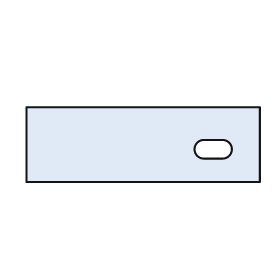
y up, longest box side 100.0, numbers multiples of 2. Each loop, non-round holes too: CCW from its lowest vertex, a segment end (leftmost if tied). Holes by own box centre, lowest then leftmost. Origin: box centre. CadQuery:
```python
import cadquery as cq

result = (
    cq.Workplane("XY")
    .moveTo(-50.0, -16.0)
    .lineTo(50.0, -16.0)
    .lineTo(50.0, 16.0)
    .lineTo(-50.0, 16.0)
    .close()
    .moveTo(26.0, -6.0)
    .lineTo(34.0, -6.0)
    .threePointArc((38.0, -2.0), (34.0, 2.0))
    .lineTo(26.0, 2.0)
    .threePointArc((22.0, -2.0), (26.0, -6.0))
    .close()
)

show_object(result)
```